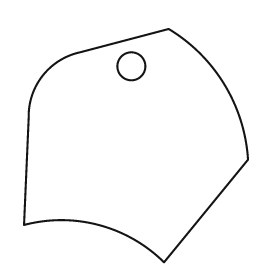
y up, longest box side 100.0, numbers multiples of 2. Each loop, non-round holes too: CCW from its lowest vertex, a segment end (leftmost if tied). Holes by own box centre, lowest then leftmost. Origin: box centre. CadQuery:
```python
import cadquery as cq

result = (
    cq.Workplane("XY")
    .moveTo(12.0, -50.0)
    .lineTo(48.0, -6.0)
    .threePointArc((38.0, 26.0), (14.0, 50.0))
    .lineTo(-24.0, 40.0)
    .threePointArc((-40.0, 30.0), (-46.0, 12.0))
    .lineTo(-48.0, -34.0)
    .threePointArc((-16.0, -34.0), (12.0, -50.0))
    .close()
    .moveTo(-2.0, 34.0)
    .circle(6.0)
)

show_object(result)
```